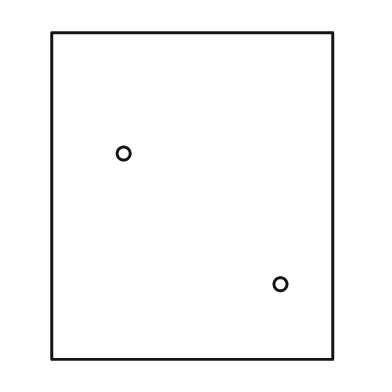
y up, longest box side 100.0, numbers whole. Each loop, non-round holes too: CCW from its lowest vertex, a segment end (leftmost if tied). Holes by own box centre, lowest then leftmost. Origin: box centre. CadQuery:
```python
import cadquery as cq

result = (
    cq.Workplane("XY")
    .moveTo(-43.0, -50.0)
    .lineTo(43.0, -50.0)
    .lineTo(43.0, 50.0)
    .lineTo(-43.0, 50.0)
    .close()
    .moveTo(27.0, -27.0)
    .circle(2.0)
    .moveTo(-21.0, 13.0)
    .circle(2.0)
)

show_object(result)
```